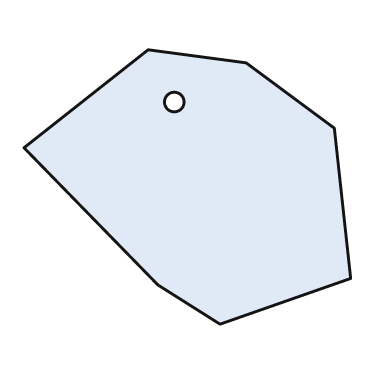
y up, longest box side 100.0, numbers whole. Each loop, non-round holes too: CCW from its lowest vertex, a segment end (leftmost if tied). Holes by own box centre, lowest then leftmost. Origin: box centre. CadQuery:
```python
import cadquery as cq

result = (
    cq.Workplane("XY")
    .moveTo(10.0, -42.0)
    .lineTo(50.0, -28.0)
    .lineTo(45.0, 18.0)
    .lineTo(18.0, 38.0)
    .lineTo(-12.0, 42.0)
    .lineTo(-50.0, 12.0)
    .lineTo(-9.0, -30.0)
    .close()
    .moveTo(-4.0, 26.0)
    .circle(3.0)
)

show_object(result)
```